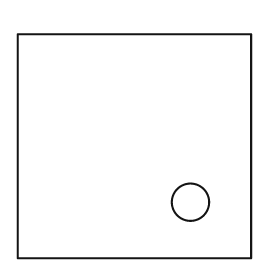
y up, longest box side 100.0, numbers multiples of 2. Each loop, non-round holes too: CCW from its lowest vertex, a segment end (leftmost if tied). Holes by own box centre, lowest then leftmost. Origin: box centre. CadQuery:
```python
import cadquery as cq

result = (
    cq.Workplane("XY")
    .moveTo(-50.0, -48.0)
    .lineTo(50.0, -48.0)
    .lineTo(50.0, 48.0)
    .lineTo(-50.0, 48.0)
    .close()
    .moveTo(24.0, -24.0)
    .circle(8.0)
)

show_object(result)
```